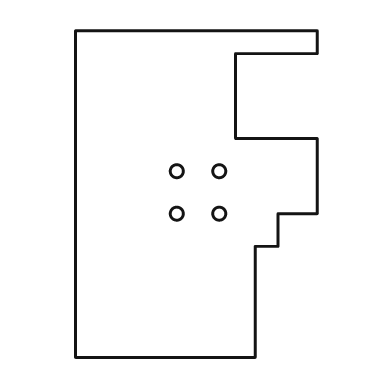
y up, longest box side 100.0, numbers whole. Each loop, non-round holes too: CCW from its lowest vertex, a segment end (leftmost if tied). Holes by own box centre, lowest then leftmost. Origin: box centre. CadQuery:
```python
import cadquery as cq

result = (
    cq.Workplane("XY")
    .moveTo(-37.0, -50.0)
    .lineTo(18.0, -50.0)
    .lineTo(18.0, -16.0)
    .lineTo(25.0, -16.0)
    .lineTo(25.0, -6.0)
    .lineTo(37.0, -6.0)
    .lineTo(37.0, 17.0)
    .lineTo(12.0, 17.0)
    .lineTo(12.0, 43.0)
    .lineTo(37.0, 43.0)
    .lineTo(37.0, 50.0)
    .lineTo(-37.0, 50.0)
    .close()
    .moveTo(-6.0, -6.0)
    .circle(2.0)
    .moveTo(7.0, -6.0)
    .circle(2.0)
    .moveTo(-6.0, 7.0)
    .circle(2.0)
    .moveTo(7.0, 7.0)
    .circle(2.0)
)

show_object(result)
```